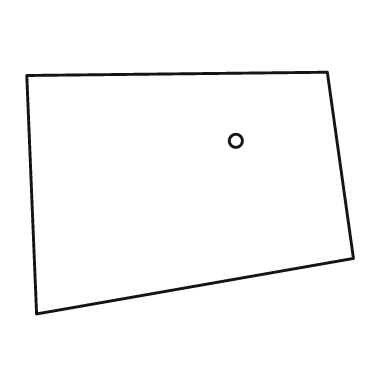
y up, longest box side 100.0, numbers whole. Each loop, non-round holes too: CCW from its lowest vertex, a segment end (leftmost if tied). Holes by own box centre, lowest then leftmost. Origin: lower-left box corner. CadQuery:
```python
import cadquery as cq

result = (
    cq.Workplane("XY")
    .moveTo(3.0, 0.0)
    .lineTo(100.0, 17.0)
    .lineTo(92.0, 74.0)
    .lineTo(0.0, 73.0)
    .close()
    .moveTo(64.0, 53.0)
    .circle(2.0)
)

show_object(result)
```